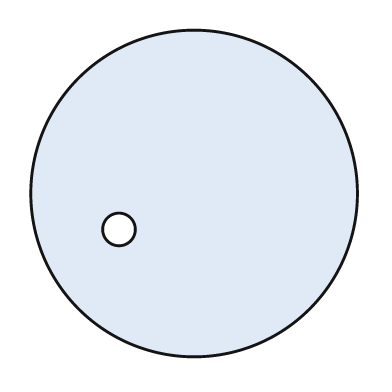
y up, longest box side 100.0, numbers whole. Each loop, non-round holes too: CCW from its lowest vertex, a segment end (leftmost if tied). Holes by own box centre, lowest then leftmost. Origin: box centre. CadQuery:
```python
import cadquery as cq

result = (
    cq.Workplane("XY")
    .moveTo(0.0, 0.0)
    .circle(50.0)
    .moveTo(-23.0, -11.0)
    .circle(5.0)
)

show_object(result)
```